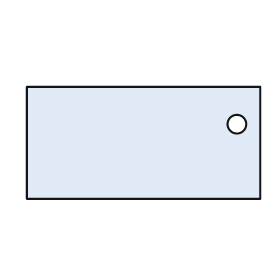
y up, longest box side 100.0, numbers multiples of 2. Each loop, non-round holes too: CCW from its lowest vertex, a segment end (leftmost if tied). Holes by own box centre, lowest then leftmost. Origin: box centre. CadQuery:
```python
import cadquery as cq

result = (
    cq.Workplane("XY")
    .moveTo(-50.0, -24.0)
    .lineTo(50.0, -24.0)
    .lineTo(50.0, 24.0)
    .lineTo(-50.0, 24.0)
    .close()
    .moveTo(40.0, 8.0)
    .circle(4.0)
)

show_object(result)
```